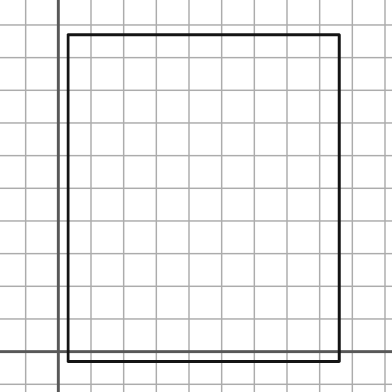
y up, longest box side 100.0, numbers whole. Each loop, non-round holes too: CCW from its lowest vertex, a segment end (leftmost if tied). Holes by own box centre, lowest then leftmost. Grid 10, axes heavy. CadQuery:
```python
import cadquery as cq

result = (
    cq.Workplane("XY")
    .moveTo(3.0, -3.0)
    .lineTo(86.0, -3.0)
    .lineTo(86.0, 97.0)
    .lineTo(3.0, 97.0)
    .close()
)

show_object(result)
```